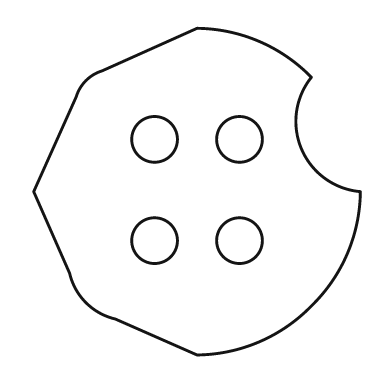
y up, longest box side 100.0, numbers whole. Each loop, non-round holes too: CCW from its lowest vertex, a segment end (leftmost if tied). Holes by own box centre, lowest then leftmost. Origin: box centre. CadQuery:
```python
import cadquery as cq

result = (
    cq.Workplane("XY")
    .moveTo(0.0, -50.0)
    .threePointArc((19.0, -46.0), (35.0, -35.0))
    .threePointArc((46.0, -19.0), (50.0, 0.0))
    .threePointArc((32.0, 13.0), (35.0, 35.0))
    .threePointArc((19.0, 46.0), (0.0, 50.0))
    .lineTo(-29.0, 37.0)
    .threePointArc((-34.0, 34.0), (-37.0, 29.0))
    .lineTo(-50.0, 0.0)
    .lineTo(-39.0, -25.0)
    .threePointArc((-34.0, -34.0), (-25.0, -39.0))
    .close()
    .moveTo(-13.0, -15.0)
    .circle(7.0)
    .moveTo(13.0, -15.0)
    .circle(7.0)
    .moveTo(-13.0, 16.0)
    .circle(7.0)
    .moveTo(13.0, 16.0)
    .circle(7.0)
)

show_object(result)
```